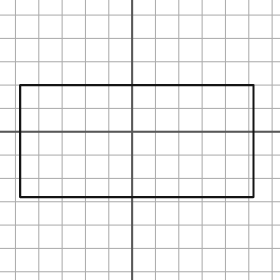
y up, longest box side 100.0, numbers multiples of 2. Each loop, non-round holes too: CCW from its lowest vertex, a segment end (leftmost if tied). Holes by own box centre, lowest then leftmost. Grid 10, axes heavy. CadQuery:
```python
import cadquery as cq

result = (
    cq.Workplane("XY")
    .moveTo(-48.0, -28.0)
    .lineTo(52.0, -28.0)
    .lineTo(52.0, 20.0)
    .lineTo(-48.0, 20.0)
    .close()
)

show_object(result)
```